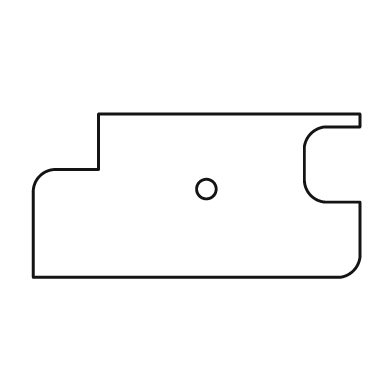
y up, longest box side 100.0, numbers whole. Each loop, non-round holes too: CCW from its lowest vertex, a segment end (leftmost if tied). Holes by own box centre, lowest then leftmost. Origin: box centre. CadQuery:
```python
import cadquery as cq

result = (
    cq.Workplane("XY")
    .moveTo(-50.0, -25.0)
    .lineTo(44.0, -25.0)
    .threePointArc((48.0, -23.0), (50.0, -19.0))
    .lineTo(50.0, -2.0)
    .lineTo(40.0, -2.0)
    .threePointArc((35.0, 0.0), (33.0, 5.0))
    .lineTo(33.0, 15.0)
    .threePointArc((35.0, 19.0), (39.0, 21.0))
    .lineTo(50.0, 21.0)
    .lineTo(50.0, 25.0)
    .lineTo(-30.0, 25.0)
    .lineTo(-30.0, 8.0)
    .lineTo(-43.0, 8.0)
    .threePointArc((-48.0, 6.0), (-50.0, 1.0))
    .close()
    .moveTo(3.0, 2.0)
    .circle(3.0)
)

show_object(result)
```